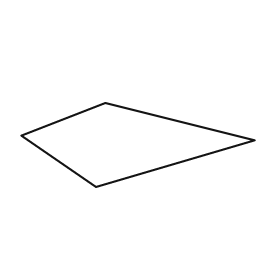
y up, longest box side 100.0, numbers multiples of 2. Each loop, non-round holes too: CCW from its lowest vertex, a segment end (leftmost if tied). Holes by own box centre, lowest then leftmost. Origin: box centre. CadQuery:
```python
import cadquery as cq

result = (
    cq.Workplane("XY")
    .moveTo(-18.0, -18.0)
    .lineTo(50.0, 2.0)
    .lineTo(-14.0, 18.0)
    .lineTo(-50.0, 4.0)
    .close()
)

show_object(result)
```